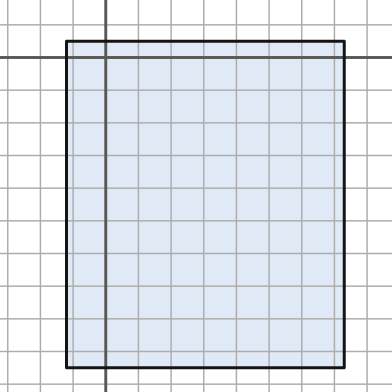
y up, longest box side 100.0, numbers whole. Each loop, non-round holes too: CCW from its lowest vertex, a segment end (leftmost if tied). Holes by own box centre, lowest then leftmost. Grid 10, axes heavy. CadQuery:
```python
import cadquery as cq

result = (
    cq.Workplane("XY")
    .moveTo(-12.0, -95.0)
    .lineTo(73.0, -95.0)
    .lineTo(73.0, 5.0)
    .lineTo(-12.0, 5.0)
    .close()
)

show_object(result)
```